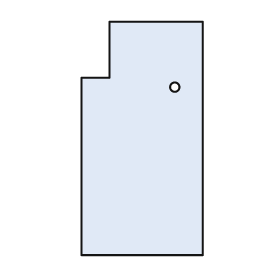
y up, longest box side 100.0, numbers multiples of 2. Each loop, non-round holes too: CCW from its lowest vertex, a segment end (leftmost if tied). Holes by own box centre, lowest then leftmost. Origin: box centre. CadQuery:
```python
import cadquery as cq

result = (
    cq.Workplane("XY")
    .moveTo(-26.0, -50.0)
    .lineTo(26.0, -50.0)
    .lineTo(26.0, 50.0)
    .lineTo(-14.0, 50.0)
    .lineTo(-14.0, 26.0)
    .lineTo(-26.0, 26.0)
    .close()
    .moveTo(14.0, 22.0)
    .circle(2.0)
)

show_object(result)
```